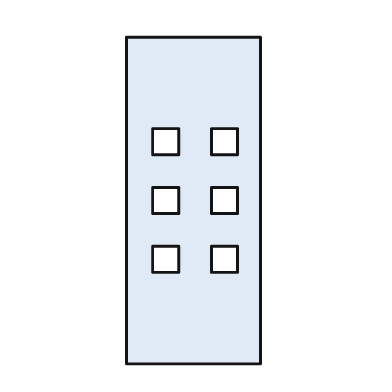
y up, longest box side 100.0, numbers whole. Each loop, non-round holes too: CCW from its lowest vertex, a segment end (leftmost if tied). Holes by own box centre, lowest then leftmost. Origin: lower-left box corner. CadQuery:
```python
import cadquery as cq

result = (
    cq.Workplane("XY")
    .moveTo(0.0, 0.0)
    .lineTo(41.0, 0.0)
    .lineTo(41.0, 100.0)
    .lineTo(0.0, 100.0)
    .close()
    .moveTo(8.0, 28.0)
    .lineTo(16.0, 28.0)
    .lineTo(16.0, 36.0)
    .lineTo(8.0, 36.0)
    .close()
    .moveTo(26.0, 28.0)
    .lineTo(34.0, 28.0)
    .lineTo(34.0, 36.0)
    .lineTo(26.0, 36.0)
    .close()
    .moveTo(8.0, 46.0)
    .lineTo(16.0, 46.0)
    .lineTo(16.0, 54.0)
    .lineTo(8.0, 54.0)
    .close()
    .moveTo(26.0, 46.0)
    .lineTo(34.0, 46.0)
    .lineTo(34.0, 54.0)
    .lineTo(26.0, 54.0)
    .close()
    .moveTo(8.0, 64.0)
    .lineTo(16.0, 64.0)
    .lineTo(16.0, 72.0)
    .lineTo(8.0, 72.0)
    .close()
    .moveTo(26.0, 64.0)
    .lineTo(34.0, 64.0)
    .lineTo(34.0, 72.0)
    .lineTo(26.0, 72.0)
    .close()
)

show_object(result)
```